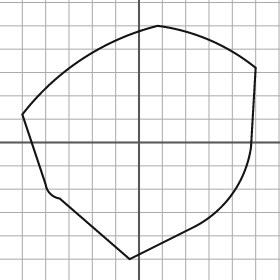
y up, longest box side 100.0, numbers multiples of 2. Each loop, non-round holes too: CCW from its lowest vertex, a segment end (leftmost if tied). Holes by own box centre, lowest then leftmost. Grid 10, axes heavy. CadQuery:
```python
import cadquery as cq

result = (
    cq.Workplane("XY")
    .moveTo(-4.0, -50.0)
    .lineTo(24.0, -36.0)
    .threePointArc((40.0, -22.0), (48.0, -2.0))
    .lineTo(50.0, 32.0)
    .threePointArc((30.0, 44.0), (8.0, 50.0))
    .threePointArc((-24.0, 36.0), (-50.0, 12.0))
    .lineTo(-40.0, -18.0)
    .threePointArc((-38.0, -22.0), (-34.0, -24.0))
    .close()
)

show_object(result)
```